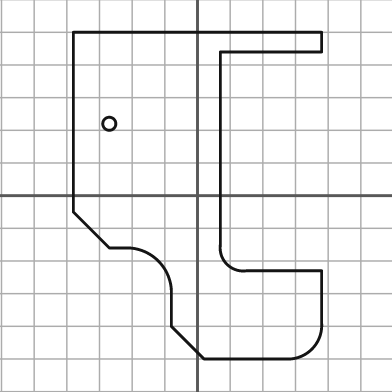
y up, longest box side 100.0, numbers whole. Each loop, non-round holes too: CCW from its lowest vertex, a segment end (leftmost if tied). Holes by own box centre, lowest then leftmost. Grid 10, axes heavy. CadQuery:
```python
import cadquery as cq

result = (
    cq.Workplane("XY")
    .moveTo(2.0, -50.0)
    .lineTo(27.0, -50.0)
    .threePointArc((35.0, -47.0), (38.0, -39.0))
    .lineTo(38.0, -23.0)
    .lineTo(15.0, -23.0)
    .threePointArc((9.0, -21.0), (7.0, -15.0))
    .lineTo(7.0, 44.0)
    .lineTo(38.0, 44.0)
    .lineTo(38.0, 50.0)
    .lineTo(-38.0, 50.0)
    .lineTo(-38.0, -5.0)
    .lineTo(-27.0, -16.0)
    .lineTo(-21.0, -16.0)
    .threePointArc((-12.0, -20.0), (-8.0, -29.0))
    .lineTo(-8.0, -40.0)
    .close()
    .moveTo(-27.0, 22.0)
    .circle(2.0)
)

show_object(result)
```